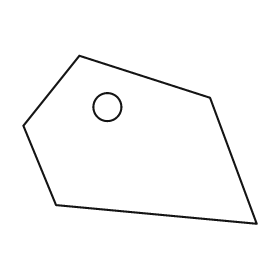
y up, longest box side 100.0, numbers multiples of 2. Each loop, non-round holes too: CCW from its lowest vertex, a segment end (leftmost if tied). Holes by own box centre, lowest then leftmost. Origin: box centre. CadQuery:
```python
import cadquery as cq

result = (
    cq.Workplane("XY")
    .moveTo(50.0, -36.0)
    .lineTo(30.0, 18.0)
    .lineTo(-26.0, 36.0)
    .lineTo(-50.0, 6.0)
    .lineTo(-36.0, -28.0)
    .close()
    .moveTo(-14.0, 14.0)
    .circle(6.0)
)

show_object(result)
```